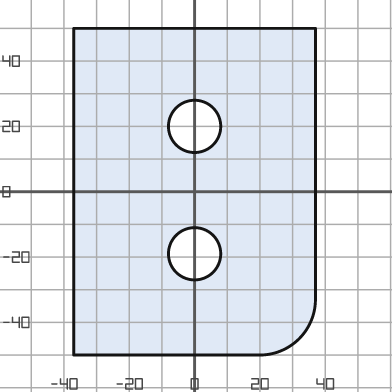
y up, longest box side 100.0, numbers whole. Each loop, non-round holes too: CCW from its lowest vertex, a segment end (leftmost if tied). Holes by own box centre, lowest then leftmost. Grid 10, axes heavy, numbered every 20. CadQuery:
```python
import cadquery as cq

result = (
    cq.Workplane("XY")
    .moveTo(-37.0, -50.0)
    .lineTo(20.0, -50.0)
    .threePointArc((32.0, -45.0), (37.0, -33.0))
    .lineTo(37.0, 50.0)
    .lineTo(-37.0, 50.0)
    .close()
    .moveTo(0.0, -19.0)
    .circle(8.0)
    .moveTo(0.0, 20.0)
    .circle(8.0)
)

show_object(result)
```